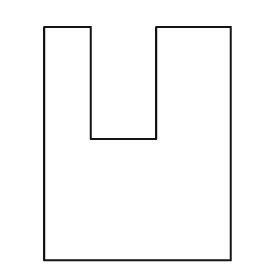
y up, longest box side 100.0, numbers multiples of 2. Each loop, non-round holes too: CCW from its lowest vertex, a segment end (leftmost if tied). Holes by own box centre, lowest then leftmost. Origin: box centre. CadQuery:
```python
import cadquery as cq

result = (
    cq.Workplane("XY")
    .moveTo(-40.0, -50.0)
    .lineTo(40.0, -50.0)
    .lineTo(40.0, 50.0)
    .lineTo(8.0, 50.0)
    .lineTo(8.0, 2.0)
    .lineTo(-20.0, 2.0)
    .lineTo(-20.0, 50.0)
    .lineTo(-40.0, 50.0)
    .close()
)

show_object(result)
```